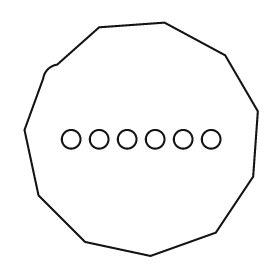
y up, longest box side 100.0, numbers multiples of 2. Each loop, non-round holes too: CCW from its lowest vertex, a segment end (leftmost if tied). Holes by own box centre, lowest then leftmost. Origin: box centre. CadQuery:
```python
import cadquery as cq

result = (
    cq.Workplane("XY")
    .moveTo(4.0, -50.0)
    .lineTo(32.0, -40.0)
    .lineTo(48.0, -16.0)
    .lineTo(50.0, 12.0)
    .lineTo(36.0, 36.0)
    .lineTo(10.0, 50.0)
    .lineTo(-18.0, 48.0)
    .lineTo(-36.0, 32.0)
    .threePointArc((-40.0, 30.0), (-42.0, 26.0))
    .lineTo(-50.0, 4.0)
    .lineTo(-44.0, -24.0)
    .lineTo(-24.0, -44.0)
    .close()
    .moveTo(-30.0, 0.0)
    .circle(4.0)
    .moveTo(-18.0, 0.0)
    .circle(4.0)
    .moveTo(-6.0, 0.0)
    .circle(4.0)
    .moveTo(6.0, 0.0)
    .circle(4.0)
    .moveTo(18.0, 0.0)
    .circle(4.0)
    .moveTo(30.0, 0.0)
    .circle(4.0)
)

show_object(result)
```